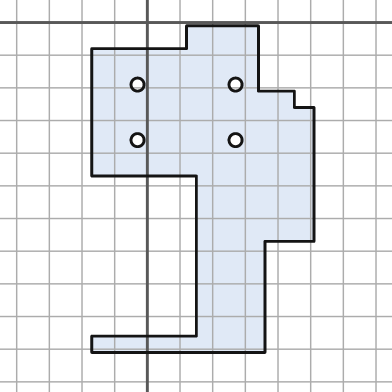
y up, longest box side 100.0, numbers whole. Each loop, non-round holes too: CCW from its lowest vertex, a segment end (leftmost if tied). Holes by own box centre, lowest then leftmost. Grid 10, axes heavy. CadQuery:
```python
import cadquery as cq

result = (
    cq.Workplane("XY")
    .moveTo(-17.0, -101.0)
    .lineTo(36.0, -101.0)
    .lineTo(36.0, -67.0)
    .lineTo(51.0, -67.0)
    .lineTo(51.0, -26.0)
    .lineTo(45.0, -26.0)
    .lineTo(45.0, -21.0)
    .lineTo(34.0, -21.0)
    .lineTo(34.0, -1.0)
    .lineTo(12.0, -1.0)
    .lineTo(12.0, -8.0)
    .lineTo(-17.0, -8.0)
    .lineTo(-17.0, -47.0)
    .lineTo(15.0, -47.0)
    .lineTo(15.0, -96.0)
    .lineTo(-17.0, -96.0)
    .close()
    .moveTo(-3.0, -36.0)
    .circle(2.0)
    .moveTo(27.0, -36.0)
    .circle(2.0)
    .moveTo(-3.0, -19.0)
    .circle(2.0)
    .moveTo(27.0, -19.0)
    .circle(2.0)
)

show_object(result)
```